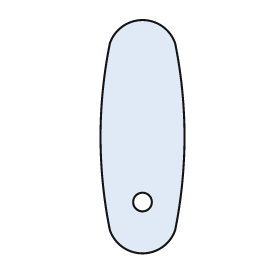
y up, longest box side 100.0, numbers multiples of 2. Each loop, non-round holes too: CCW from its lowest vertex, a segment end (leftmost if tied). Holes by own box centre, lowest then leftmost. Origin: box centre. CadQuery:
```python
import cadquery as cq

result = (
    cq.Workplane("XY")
    .moveTo(-14.0, -40.0)
    .threePointArc((0.0, -50.0), (14.0, -40.0))
    .threePointArc((18.0, 0.0), (14.0, 40.0))
    .threePointArc((0.0, 50.0), (-14.0, 40.0))
    .threePointArc((-18.0, 0.0), (-14.0, -40.0))
    .close()
    .moveTo(0.0, -28.0)
    .circle(4.0)
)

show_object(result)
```